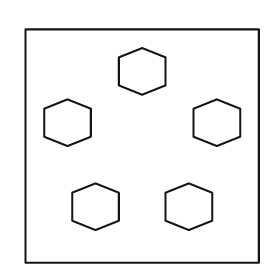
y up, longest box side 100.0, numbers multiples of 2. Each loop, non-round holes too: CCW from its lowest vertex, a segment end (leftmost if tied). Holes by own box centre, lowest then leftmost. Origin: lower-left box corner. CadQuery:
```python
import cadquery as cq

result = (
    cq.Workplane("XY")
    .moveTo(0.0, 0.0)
    .lineTo(100.0, 0.0)
    .lineTo(100.0, 100.0)
    .lineTo(0.0, 100.0)
    .close()
    .moveTo(30.0, 14.0)
    .lineTo(40.0, 18.0)
    .lineTo(40.0, 30.0)
    .lineTo(30.0, 34.0)
    .lineTo(20.0, 30.0)
    .lineTo(20.0, 18.0)
    .close()
    .moveTo(70.0, 14.0)
    .lineTo(80.0, 18.0)
    .lineTo(80.0, 30.0)
    .lineTo(70.0, 34.0)
    .lineTo(60.0, 30.0)
    .lineTo(60.0, 18.0)
    .close()
    .moveTo(18.0, 50.0)
    .lineTo(28.0, 54.0)
    .lineTo(28.0, 66.0)
    .lineTo(18.0, 70.0)
    .lineTo(8.0, 66.0)
    .lineTo(8.0, 54.0)
    .close()
    .moveTo(82.0, 50.0)
    .lineTo(92.0, 54.0)
    .lineTo(92.0, 66.0)
    .lineTo(82.0, 70.0)
    .lineTo(72.0, 66.0)
    .lineTo(72.0, 54.0)
    .close()
    .moveTo(50.0, 72.0)
    .lineTo(60.0, 76.0)
    .lineTo(60.0, 88.0)
    .lineTo(50.0, 92.0)
    .lineTo(40.0, 88.0)
    .lineTo(40.0, 76.0)
    .close()
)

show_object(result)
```